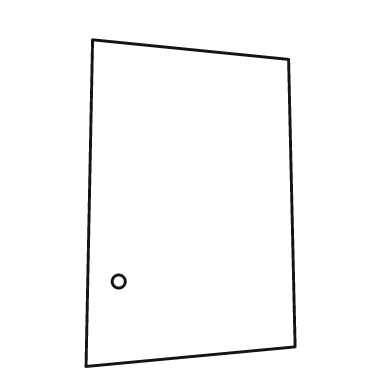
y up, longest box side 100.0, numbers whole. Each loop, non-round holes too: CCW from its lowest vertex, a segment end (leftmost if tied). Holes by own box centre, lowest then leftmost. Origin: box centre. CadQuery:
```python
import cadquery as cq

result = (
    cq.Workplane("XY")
    .moveTo(-32.0, -50.0)
    .lineTo(32.0, -44.0)
    .lineTo(30.0, 44.0)
    .lineTo(-30.0, 50.0)
    .close()
    .moveTo(-22.0, -24.0)
    .circle(2.0)
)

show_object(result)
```